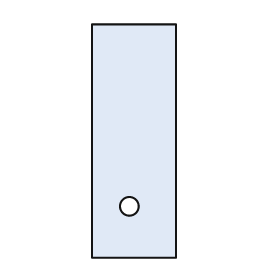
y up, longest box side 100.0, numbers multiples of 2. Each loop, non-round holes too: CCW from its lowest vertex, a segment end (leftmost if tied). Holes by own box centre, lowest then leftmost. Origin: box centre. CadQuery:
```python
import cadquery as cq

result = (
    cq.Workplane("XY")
    .moveTo(-18.0, -50.0)
    .lineTo(18.0, -50.0)
    .lineTo(18.0, 50.0)
    .lineTo(-18.0, 50.0)
    .close()
    .moveTo(-2.0, -28.0)
    .circle(4.0)
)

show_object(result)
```